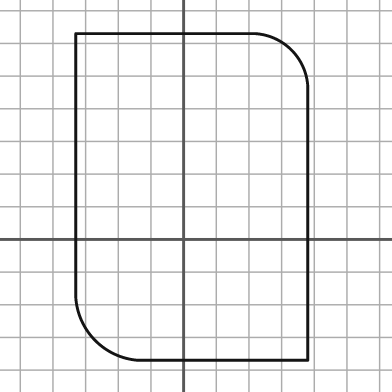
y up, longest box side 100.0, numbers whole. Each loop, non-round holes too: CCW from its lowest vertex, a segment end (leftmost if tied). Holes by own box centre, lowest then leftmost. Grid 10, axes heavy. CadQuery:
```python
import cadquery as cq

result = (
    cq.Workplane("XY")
    .moveTo(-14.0, -37.0)
    .lineTo(38.0, -37.0)
    .lineTo(38.0, 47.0)
    .threePointArc((33.0, 58.0), (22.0, 63.0))
    .lineTo(-33.0, 63.0)
    .lineTo(-33.0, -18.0)
    .threePointArc((-27.0, -31.0), (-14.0, -37.0))
    .close()
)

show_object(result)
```